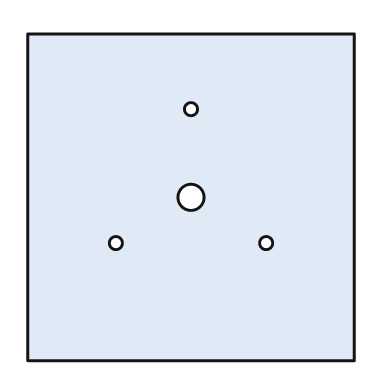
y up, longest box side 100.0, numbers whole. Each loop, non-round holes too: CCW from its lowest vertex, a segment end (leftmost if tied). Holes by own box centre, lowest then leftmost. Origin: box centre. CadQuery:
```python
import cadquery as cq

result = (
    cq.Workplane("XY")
    .moveTo(-50.0, -50.0)
    .lineTo(50.0, -50.0)
    .lineTo(50.0, 50.0)
    .lineTo(-50.0, 50.0)
    .close()
    .moveTo(-23.0, -14.0)
    .circle(2.0)
    .moveTo(23.0, -14.0)
    .circle(2.0)
    .moveTo(0.0, 0.0)
    .circle(4.0)
    .moveTo(0.0, 27.0)
    .circle(2.0)
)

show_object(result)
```